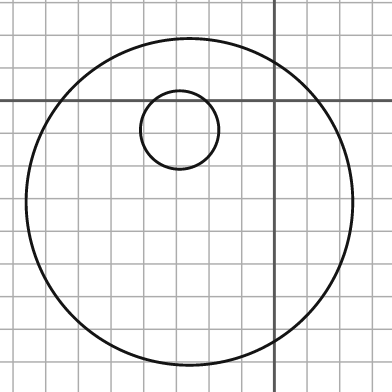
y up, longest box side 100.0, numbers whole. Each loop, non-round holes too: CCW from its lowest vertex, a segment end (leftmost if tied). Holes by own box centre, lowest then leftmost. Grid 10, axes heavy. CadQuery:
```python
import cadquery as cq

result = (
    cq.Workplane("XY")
    .moveTo(-26.0, -31.0)
    .circle(50.0)
    .moveTo(-29.0, -9.0)
    .circle(12.0)
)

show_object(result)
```